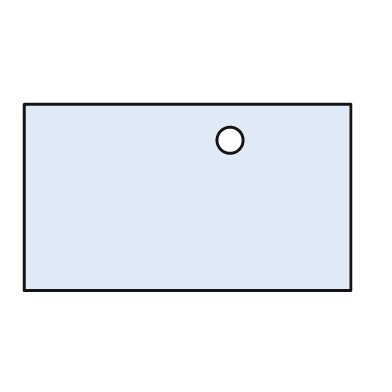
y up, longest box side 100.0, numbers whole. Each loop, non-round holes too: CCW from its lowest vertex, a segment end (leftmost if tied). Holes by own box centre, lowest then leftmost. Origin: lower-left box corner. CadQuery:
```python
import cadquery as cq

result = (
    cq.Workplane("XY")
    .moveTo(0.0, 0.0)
    .lineTo(100.0, 0.0)
    .lineTo(100.0, 57.0)
    .lineTo(0.0, 57.0)
    .close()
    .moveTo(63.0, 46.0)
    .circle(4.0)
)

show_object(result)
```